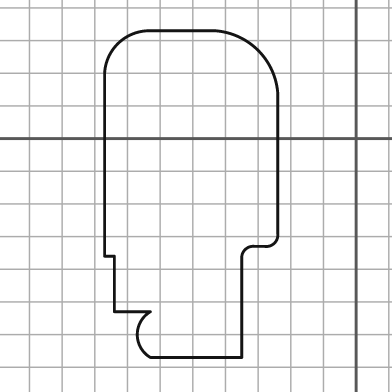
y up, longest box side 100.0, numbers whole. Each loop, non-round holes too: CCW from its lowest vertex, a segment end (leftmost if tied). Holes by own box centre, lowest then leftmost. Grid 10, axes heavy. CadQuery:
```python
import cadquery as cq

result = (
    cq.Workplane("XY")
    .moveTo(-63.0, -67.0)
    .lineTo(-35.0, -67.0)
    .lineTo(-35.0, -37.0)
    .threePointArc((-34.0, -34.0), (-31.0, -33.0))
    .lineTo(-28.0, -33.0)
    .threePointArc((-25.0, -32.0), (-24.0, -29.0))
    .lineTo(-24.0, 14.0)
    .threePointArc((-30.0, 27.0), (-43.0, 33.0))
    .lineTo(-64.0, 33.0)
    .threePointArc((-73.0, 29.0), (-77.0, 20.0))
    .lineTo(-77.0, -36.0)
    .lineTo(-74.0, -36.0)
    .lineTo(-74.0, -53.0)
    .lineTo(-63.0, -53.0)
    .threePointArc((-67.0, -60.0), (-63.0, -67.0))
    .close()
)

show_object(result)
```